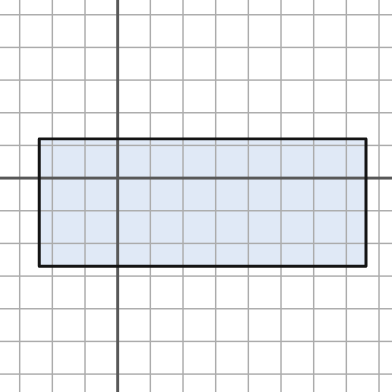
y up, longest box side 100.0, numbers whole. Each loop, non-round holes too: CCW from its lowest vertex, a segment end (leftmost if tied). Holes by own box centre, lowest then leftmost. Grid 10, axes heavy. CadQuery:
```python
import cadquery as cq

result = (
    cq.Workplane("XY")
    .moveTo(-24.0, -27.0)
    .lineTo(76.0, -27.0)
    .lineTo(76.0, 12.0)
    .lineTo(-24.0, 12.0)
    .close()
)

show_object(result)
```